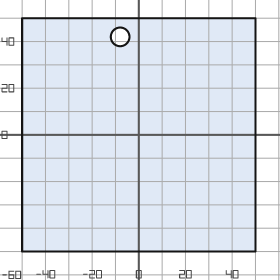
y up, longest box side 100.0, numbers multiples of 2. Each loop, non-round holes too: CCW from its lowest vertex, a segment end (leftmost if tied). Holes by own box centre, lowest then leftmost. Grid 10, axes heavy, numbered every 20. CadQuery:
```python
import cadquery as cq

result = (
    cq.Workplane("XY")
    .moveTo(-50.0, -50.0)
    .lineTo(50.0, -50.0)
    .lineTo(50.0, 50.0)
    .lineTo(-50.0, 50.0)
    .close()
    .moveTo(-8.0, 42.0)
    .circle(4.0)
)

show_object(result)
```